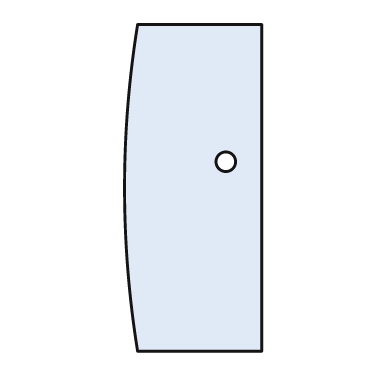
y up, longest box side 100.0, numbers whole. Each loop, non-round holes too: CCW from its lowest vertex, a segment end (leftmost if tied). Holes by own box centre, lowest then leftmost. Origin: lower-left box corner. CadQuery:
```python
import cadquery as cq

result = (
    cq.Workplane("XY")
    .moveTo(4.0, 0.0)
    .lineTo(42.0, 0.0)
    .lineTo(42.0, 100.0)
    .lineTo(4.0, 100.0)
    .threePointArc((0.0, 50.0), (4.0, 0.0))
    .close()
    .moveTo(31.0, 58.0)
    .circle(3.0)
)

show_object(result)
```